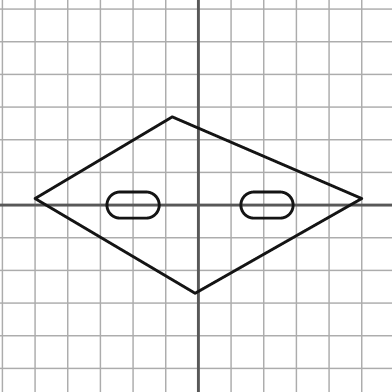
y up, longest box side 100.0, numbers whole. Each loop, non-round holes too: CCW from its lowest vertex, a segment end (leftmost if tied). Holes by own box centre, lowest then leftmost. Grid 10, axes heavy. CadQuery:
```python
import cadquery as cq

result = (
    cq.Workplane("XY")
    .moveTo(-1.0, -27.0)
    .lineTo(50.0, 2.0)
    .lineTo(-8.0, 27.0)
    .lineTo(-50.0, 2.0)
    .close()
    .moveTo(-24.0, -4.0)
    .lineTo(-16.0, -4.0)
    .threePointArc((-12.0, 0.0), (-16.0, 4.0))
    .lineTo(-24.0, 4.0)
    .threePointArc((-28.0, 0.0), (-24.0, -4.0))
    .close()
    .moveTo(17.0, -4.0)
    .lineTo(25.0, -4.0)
    .threePointArc((29.0, 0.0), (25.0, 4.0))
    .lineTo(17.0, 4.0)
    .threePointArc((13.0, 0.0), (17.0, -4.0))
    .close()
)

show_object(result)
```